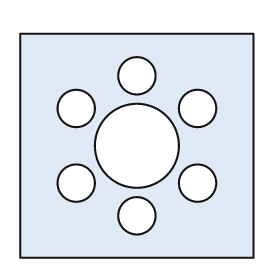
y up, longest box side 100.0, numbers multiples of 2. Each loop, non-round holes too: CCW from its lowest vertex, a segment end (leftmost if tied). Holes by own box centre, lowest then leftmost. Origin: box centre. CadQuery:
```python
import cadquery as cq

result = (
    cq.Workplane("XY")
    .moveTo(-50.0, -48.0)
    .lineTo(50.0, -48.0)
    .lineTo(50.0, 48.0)
    .lineTo(-50.0, 48.0)
    .close()
    .moveTo(0.0, -30.0)
    .circle(8.0)
    .moveTo(-26.0, -16.0)
    .circle(8.0)
    .moveTo(26.0, -16.0)
    .circle(8.0)
    .moveTo(0.0, 0.0)
    .circle(18.0)
    .moveTo(-26.0, 16.0)
    .circle(8.0)
    .moveTo(26.0, 16.0)
    .circle(8.0)
    .moveTo(0.0, 30.0)
    .circle(8.0)
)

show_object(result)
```